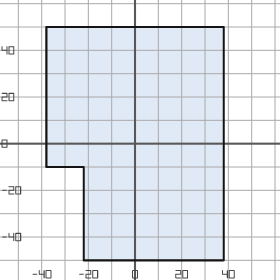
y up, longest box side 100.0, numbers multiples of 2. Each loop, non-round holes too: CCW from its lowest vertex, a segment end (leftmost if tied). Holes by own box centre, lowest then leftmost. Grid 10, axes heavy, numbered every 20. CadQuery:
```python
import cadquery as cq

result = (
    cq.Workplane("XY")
    .moveTo(-22.0, -50.0)
    .lineTo(38.0, -50.0)
    .lineTo(38.0, 50.0)
    .lineTo(-38.0, 50.0)
    .lineTo(-38.0, -10.0)
    .lineTo(-22.0, -10.0)
    .close()
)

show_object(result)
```